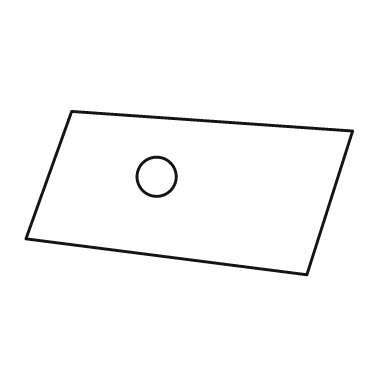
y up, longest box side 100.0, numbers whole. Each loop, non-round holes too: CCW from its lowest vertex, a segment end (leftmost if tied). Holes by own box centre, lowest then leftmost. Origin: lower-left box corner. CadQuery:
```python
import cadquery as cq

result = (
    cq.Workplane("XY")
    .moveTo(86.0, 0.0)
    .lineTo(100.0, 44.0)
    .lineTo(14.0, 50.0)
    .lineTo(0.0, 11.0)
    .close()
    .moveTo(40.0, 30.0)
    .circle(6.0)
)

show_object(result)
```